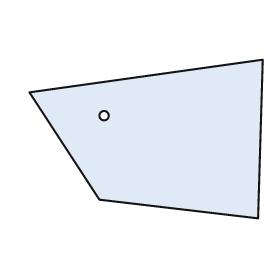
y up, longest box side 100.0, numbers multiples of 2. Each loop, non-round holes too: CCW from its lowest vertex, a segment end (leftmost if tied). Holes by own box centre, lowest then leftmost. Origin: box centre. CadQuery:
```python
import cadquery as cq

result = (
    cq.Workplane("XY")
    .moveTo(48.0, -34.0)
    .lineTo(50.0, 34.0)
    .lineTo(-50.0, 20.0)
    .lineTo(-20.0, -26.0)
    .close()
    .moveTo(-18.0, 10.0)
    .circle(2.0)
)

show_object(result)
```